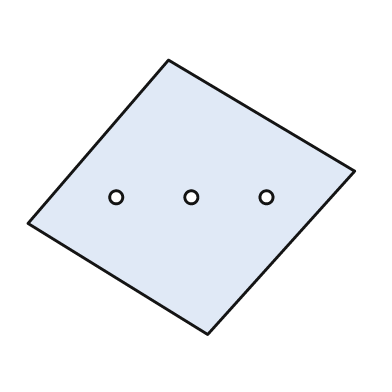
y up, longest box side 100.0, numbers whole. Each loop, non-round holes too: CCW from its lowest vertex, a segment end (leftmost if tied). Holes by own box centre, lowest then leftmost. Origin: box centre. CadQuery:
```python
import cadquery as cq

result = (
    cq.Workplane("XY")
    .moveTo(5.0, -42.0)
    .lineTo(50.0, 8.0)
    .lineTo(-7.0, 42.0)
    .lineTo(-50.0, -8.0)
    .close()
    .moveTo(-23.0, 0.0)
    .circle(2.0)
    .moveTo(0.0, 0.0)
    .circle(2.0)
    .moveTo(23.0, 0.0)
    .circle(2.0)
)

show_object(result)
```